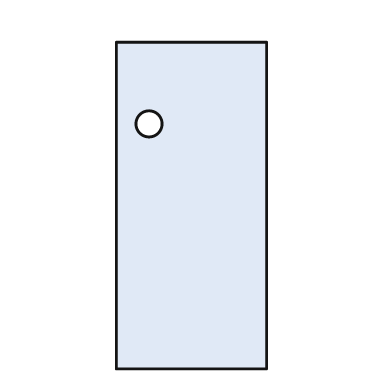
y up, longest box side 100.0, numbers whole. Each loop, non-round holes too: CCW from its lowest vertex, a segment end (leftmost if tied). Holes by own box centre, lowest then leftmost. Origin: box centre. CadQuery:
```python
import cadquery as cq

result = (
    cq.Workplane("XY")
    .moveTo(-23.0, -50.0)
    .lineTo(23.0, -50.0)
    .lineTo(23.0, 50.0)
    .lineTo(-23.0, 50.0)
    .close()
    .moveTo(-13.0, 25.0)
    .circle(4.0)
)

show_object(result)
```